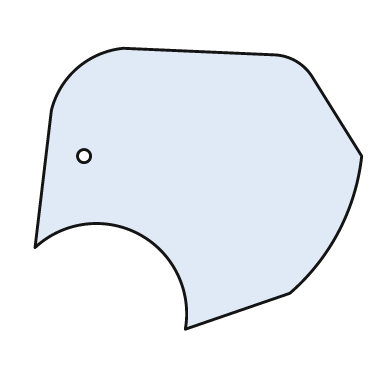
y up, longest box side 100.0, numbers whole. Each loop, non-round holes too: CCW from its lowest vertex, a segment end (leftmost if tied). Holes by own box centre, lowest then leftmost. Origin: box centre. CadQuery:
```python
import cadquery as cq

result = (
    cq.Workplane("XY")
    .moveTo(-4.0, -43.0)
    .lineTo(28.0, -32.0)
    .threePointArc((43.0, -13.0), (50.0, 10.0))
    .lineTo(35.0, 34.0)
    .threePointArc((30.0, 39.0), (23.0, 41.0))
    .lineTo(-23.0, 43.0)
    .threePointArc((-37.0, 37.0), (-45.0, 24.0))
    .lineTo(-50.0, -18.0)
    .threePointArc((-18.0, -14.0), (-4.0, -43.0))
    .close()
    .moveTo(-35.0, 10.0)
    .circle(2.0)
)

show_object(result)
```